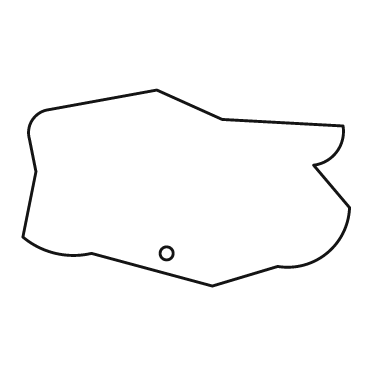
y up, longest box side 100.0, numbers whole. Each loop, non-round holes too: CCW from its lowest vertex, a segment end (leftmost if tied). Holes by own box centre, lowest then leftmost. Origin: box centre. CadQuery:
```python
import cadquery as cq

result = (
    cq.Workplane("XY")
    .moveTo(8.0, -30.0)
    .lineTo(28.0, -24.0)
    .threePointArc((43.0, -20.0), (50.0, -6.0))
    .lineTo(39.0, 7.0)
    .threePointArc((46.0, 11.0), (48.0, 19.0))
    .lineTo(11.0, 21.0)
    .lineTo(-9.0, 30.0)
    .lineTo(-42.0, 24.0)
    .threePointArc((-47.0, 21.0), (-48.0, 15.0))
    .lineTo(-46.0, 5.0)
    .lineTo(-50.0, -15.0)
    .threePointArc((-40.0, -20.0), (-29.0, -20.0))
    .close()
    .moveTo(-6.0, -20.0)
    .circle(2.0)
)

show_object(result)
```